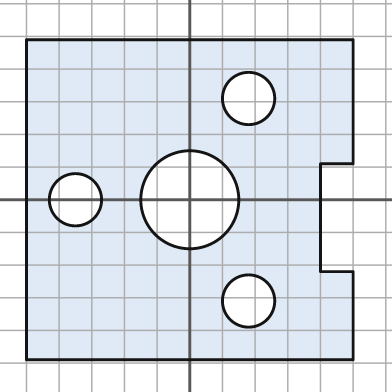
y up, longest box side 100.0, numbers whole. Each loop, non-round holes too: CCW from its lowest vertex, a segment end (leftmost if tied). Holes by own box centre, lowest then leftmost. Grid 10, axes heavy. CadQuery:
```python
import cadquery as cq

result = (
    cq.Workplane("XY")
    .moveTo(-50.0, -49.0)
    .lineTo(50.0, -49.0)
    .lineTo(50.0, -22.0)
    .lineTo(40.0, -22.0)
    .lineTo(40.0, 11.0)
    .lineTo(50.0, 11.0)
    .lineTo(50.0, 49.0)
    .lineTo(-50.0, 49.0)
    .close()
    .moveTo(18.0, -31.0)
    .circle(8.0)
    .moveTo(-35.0, 0.0)
    .circle(8.0)
    .moveTo(0.0, 0.0)
    .circle(15.0)
    .moveTo(18.0, 31.0)
    .circle(8.0)
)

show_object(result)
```